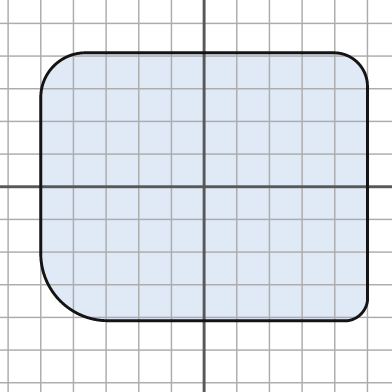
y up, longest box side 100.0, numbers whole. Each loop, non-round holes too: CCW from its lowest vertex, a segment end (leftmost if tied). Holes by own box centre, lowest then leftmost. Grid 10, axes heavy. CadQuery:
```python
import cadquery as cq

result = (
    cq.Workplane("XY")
    .moveTo(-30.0, -41.0)
    .lineTo(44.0, -41.0)
    .threePointArc((48.0, -39.0), (50.0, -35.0))
    .lineTo(50.0, 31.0)
    .threePointArc((47.0, 38.0), (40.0, 41.0))
    .lineTo(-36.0, 41.0)
    .threePointArc((-46.0, 37.0), (-50.0, 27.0))
    .lineTo(-50.0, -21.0)
    .threePointArc((-44.0, -35.0), (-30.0, -41.0))
    .close()
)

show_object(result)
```